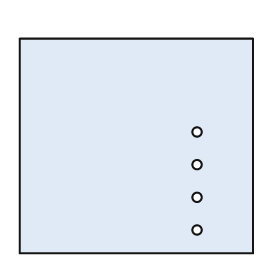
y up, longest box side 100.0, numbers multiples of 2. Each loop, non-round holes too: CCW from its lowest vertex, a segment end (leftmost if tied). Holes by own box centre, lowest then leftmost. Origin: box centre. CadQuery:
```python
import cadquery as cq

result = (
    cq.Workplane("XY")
    .moveTo(-50.0, -46.0)
    .lineTo(50.0, -46.0)
    .lineTo(50.0, 46.0)
    .lineTo(-50.0, 46.0)
    .close()
    .moveTo(26.0, -36.0)
    .circle(2.0)
    .moveTo(26.0, -22.0)
    .circle(2.0)
    .moveTo(26.0, -8.0)
    .circle(2.0)
    .moveTo(26.0, 6.0)
    .circle(2.0)
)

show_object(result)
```